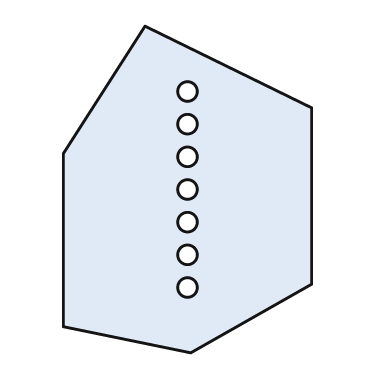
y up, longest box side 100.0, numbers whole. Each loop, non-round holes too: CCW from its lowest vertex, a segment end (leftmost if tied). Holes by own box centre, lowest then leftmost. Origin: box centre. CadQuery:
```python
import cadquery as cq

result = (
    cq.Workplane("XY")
    .moveTo(1.0, -50.0)
    .lineTo(38.0, -29.0)
    .lineTo(38.0, 25.0)
    .lineTo(-13.0, 50.0)
    .lineTo(-38.0, 11.0)
    .lineTo(-38.0, -42.0)
    .close()
    .moveTo(0.0, -30.0)
    .circle(3.0)
    .moveTo(0.0, -20.0)
    .circle(3.0)
    .moveTo(0.0, -10.0)
    .circle(3.0)
    .moveTo(0.0, 0.0)
    .circle(3.0)
    .moveTo(0.0, 10.0)
    .circle(3.0)
    .moveTo(0.0, 20.0)
    .circle(3.0)
    .moveTo(0.0, 30.0)
    .circle(3.0)
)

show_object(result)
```